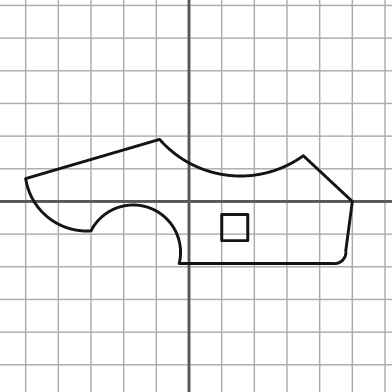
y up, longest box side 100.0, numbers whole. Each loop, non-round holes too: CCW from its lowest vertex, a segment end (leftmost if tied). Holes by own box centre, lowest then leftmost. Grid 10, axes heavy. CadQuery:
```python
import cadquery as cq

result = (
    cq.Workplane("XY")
    .moveTo(-3.0, -19.0)
    .lineTo(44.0, -19.0)
    .threePointArc((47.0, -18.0), (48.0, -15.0))
    .lineTo(50.0, 0.0)
    .lineTo(35.0, 14.0)
    .threePointArc((12.0, 8.0), (-9.0, 19.0))
    .lineTo(-50.0, 7.0)
    .threePointArc((-43.0, -5.0), (-30.0, -9.0))
    .threePointArc((-12.0, -2.0), (-3.0, -19.0))
    .close()
    .moveTo(10.0, -12.0)
    .lineTo(18.0, -12.0)
    .lineTo(18.0, -4.0)
    .lineTo(10.0, -4.0)
    .close()
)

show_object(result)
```